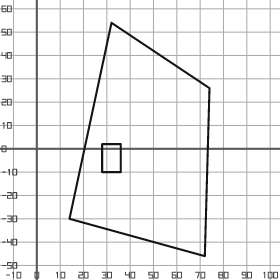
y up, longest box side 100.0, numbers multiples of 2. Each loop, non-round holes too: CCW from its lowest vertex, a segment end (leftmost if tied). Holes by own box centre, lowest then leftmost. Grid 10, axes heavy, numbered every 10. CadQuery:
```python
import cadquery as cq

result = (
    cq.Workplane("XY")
    .moveTo(72.0, -46.0)
    .lineTo(74.0, 26.0)
    .lineTo(32.0, 54.0)
    .lineTo(14.0, -30.0)
    .close()
    .moveTo(28.0, -10.0)
    .lineTo(36.0, -10.0)
    .lineTo(36.0, 2.0)
    .lineTo(28.0, 2.0)
    .close()
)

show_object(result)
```